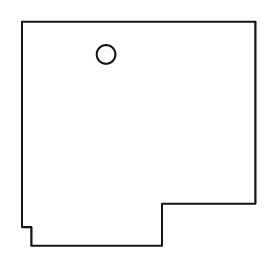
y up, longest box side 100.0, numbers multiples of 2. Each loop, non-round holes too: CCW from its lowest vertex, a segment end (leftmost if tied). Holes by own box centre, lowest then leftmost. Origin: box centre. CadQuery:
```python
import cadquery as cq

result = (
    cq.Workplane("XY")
    .moveTo(-46.0, -48.0)
    .lineTo(10.0, -48.0)
    .lineTo(10.0, -30.0)
    .lineTo(50.0, -30.0)
    .lineTo(50.0, 48.0)
    .lineTo(-50.0, 48.0)
    .lineTo(-50.0, -40.0)
    .lineTo(-46.0, -40.0)
    .close()
    .moveTo(-14.0, 34.0)
    .circle(4.0)
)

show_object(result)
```